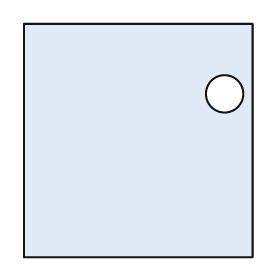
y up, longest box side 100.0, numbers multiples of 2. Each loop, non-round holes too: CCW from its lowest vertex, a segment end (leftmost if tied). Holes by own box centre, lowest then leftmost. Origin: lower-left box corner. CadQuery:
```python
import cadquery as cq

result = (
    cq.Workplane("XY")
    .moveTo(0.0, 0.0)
    .lineTo(98.0, 0.0)
    .lineTo(98.0, 100.0)
    .lineTo(0.0, 100.0)
    .close()
    .moveTo(86.0, 70.0)
    .circle(8.0)
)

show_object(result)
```